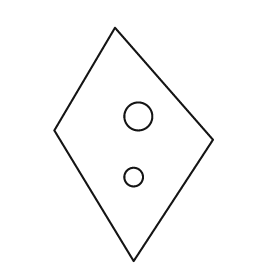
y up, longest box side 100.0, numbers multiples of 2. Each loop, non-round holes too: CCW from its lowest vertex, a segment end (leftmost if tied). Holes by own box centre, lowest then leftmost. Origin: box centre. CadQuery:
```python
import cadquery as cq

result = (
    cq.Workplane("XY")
    .moveTo(0.0, -50.0)
    .lineTo(34.0, 2.0)
    .lineTo(-8.0, 50.0)
    .lineTo(-34.0, 6.0)
    .close()
    .moveTo(0.0, -14.0)
    .circle(4.0)
    .moveTo(2.0, 12.0)
    .circle(6.0)
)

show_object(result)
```